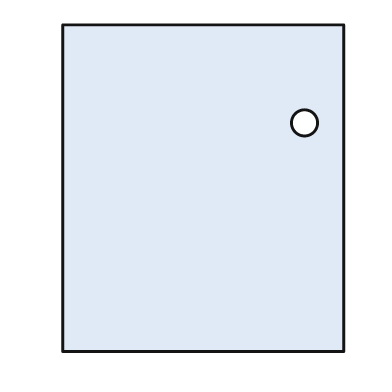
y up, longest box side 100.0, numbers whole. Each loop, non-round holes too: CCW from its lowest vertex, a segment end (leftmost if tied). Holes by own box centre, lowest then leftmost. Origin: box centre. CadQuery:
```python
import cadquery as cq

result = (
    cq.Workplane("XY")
    .moveTo(-43.0, -50.0)
    .lineTo(43.0, -50.0)
    .lineTo(43.0, 50.0)
    .lineTo(-43.0, 50.0)
    .close()
    .moveTo(31.0, 20.0)
    .circle(4.0)
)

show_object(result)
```